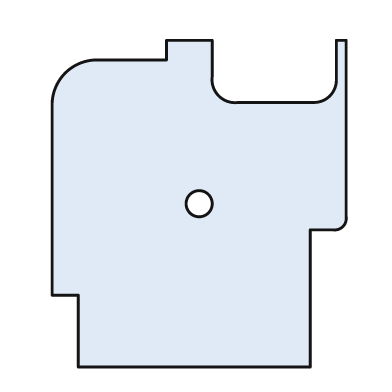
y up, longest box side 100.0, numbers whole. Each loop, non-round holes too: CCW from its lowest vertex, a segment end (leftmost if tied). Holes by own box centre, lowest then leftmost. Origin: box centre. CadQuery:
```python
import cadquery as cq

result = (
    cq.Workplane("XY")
    .moveTo(-37.0, -50.0)
    .lineTo(34.0, -50.0)
    .lineTo(34.0, -8.0)
    .lineTo(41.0, -8.0)
    .threePointArc((44.0, -7.0), (45.0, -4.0))
    .lineTo(45.0, 50.0)
    .lineTo(42.0, 50.0)
    .lineTo(42.0, 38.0)
    .threePointArc((40.0, 33.0), (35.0, 31.0))
    .lineTo(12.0, 31.0)
    .threePointArc((6.0, 33.0), (4.0, 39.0))
    .lineTo(4.0, 50.0)
    .lineTo(-10.0, 50.0)
    .lineTo(-10.0, 44.0)
    .lineTo(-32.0, 44.0)
    .threePointArc((-41.0, 40.0), (-45.0, 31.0))
    .lineTo(-45.0, -28.0)
    .lineTo(-37.0, -28.0)
    .close()
    .moveTo(0.0, 0.0)
    .circle(4.0)
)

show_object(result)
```